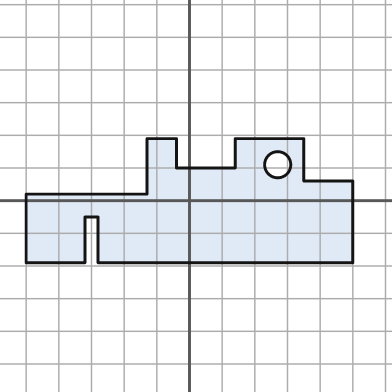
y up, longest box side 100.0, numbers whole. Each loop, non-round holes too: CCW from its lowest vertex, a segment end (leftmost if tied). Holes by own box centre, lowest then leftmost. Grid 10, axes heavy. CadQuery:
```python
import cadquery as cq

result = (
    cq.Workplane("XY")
    .moveTo(-50.0, -19.0)
    .lineTo(-32.0, -19.0)
    .lineTo(-32.0, -5.0)
    .lineTo(-28.0, -5.0)
    .lineTo(-28.0, -19.0)
    .lineTo(50.0, -19.0)
    .lineTo(50.0, 6.0)
    .lineTo(35.0, 6.0)
    .lineTo(35.0, 19.0)
    .lineTo(14.0, 19.0)
    .lineTo(14.0, 10.0)
    .lineTo(-4.0, 10.0)
    .lineTo(-4.0, 19.0)
    .lineTo(-13.0, 19.0)
    .lineTo(-13.0, 2.0)
    .lineTo(-50.0, 2.0)
    .close()
    .moveTo(27.0, 11.0)
    .circle(4.0)
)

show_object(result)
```